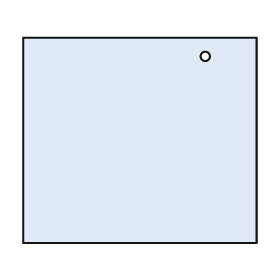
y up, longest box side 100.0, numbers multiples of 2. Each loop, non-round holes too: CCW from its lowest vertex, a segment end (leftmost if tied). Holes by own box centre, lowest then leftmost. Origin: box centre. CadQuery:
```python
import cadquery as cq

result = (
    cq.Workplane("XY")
    .moveTo(-50.0, -44.0)
    .lineTo(50.0, -44.0)
    .lineTo(50.0, 44.0)
    .lineTo(-50.0, 44.0)
    .close()
    .moveTo(28.0, 36.0)
    .circle(2.0)
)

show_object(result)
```